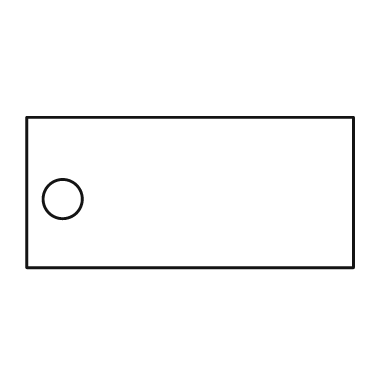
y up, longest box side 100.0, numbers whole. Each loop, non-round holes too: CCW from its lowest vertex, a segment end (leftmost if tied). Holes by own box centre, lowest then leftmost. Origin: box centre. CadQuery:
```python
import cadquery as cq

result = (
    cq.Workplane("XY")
    .moveTo(-50.0, -23.0)
    .lineTo(50.0, -23.0)
    .lineTo(50.0, 23.0)
    .lineTo(-50.0, 23.0)
    .close()
    .moveTo(-39.0, -2.0)
    .circle(6.0)
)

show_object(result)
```